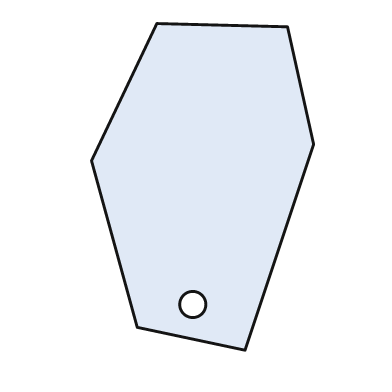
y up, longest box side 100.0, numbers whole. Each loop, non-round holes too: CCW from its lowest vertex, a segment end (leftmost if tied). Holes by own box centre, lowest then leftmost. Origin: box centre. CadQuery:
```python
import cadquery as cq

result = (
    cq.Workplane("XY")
    .moveTo(13.0, -50.0)
    .lineTo(34.0, 13.0)
    .lineTo(26.0, 49.0)
    .lineTo(-14.0, 50.0)
    .lineTo(-34.0, 8.0)
    .lineTo(-20.0, -43.0)
    .close()
    .moveTo(-3.0, -36.0)
    .circle(4.0)
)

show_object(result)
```